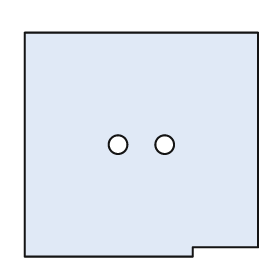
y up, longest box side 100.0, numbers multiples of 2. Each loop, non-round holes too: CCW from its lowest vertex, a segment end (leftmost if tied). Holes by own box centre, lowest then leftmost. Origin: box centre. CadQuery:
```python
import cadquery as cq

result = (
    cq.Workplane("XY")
    .moveTo(-50.0, -48.0)
    .lineTo(22.0, -48.0)
    .lineTo(22.0, -44.0)
    .lineTo(50.0, -44.0)
    .lineTo(50.0, 48.0)
    .lineTo(-50.0, 48.0)
    .close()
    .moveTo(-10.0, 0.0)
    .circle(4.0)
    .moveTo(10.0, 0.0)
    .circle(4.0)
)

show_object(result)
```